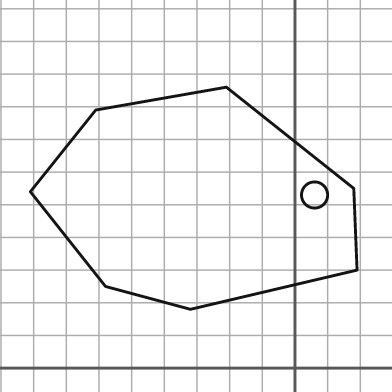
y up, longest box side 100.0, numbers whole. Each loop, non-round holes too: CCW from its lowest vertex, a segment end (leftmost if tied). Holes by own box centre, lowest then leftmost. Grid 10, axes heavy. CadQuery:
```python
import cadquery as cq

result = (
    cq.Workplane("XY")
    .moveTo(-32.0, 18.0)
    .lineTo(19.0, 30.0)
    .lineTo(18.0, 55.0)
    .lineTo(-21.0, 86.0)
    .lineTo(-61.0, 79.0)
    .lineTo(-81.0, 54.0)
    .lineTo(-58.0, 25.0)
    .close()
    .moveTo(6.0, 53.0)
    .circle(4.0)
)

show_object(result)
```